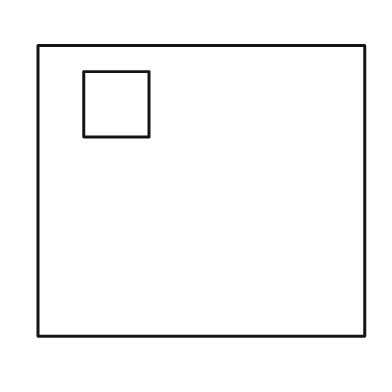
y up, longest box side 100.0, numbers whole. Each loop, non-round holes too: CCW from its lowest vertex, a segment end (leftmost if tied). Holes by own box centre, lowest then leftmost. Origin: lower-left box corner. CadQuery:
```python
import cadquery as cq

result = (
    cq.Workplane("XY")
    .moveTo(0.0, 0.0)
    .lineTo(100.0, 0.0)
    .lineTo(100.0, 89.0)
    .lineTo(0.0, 89.0)
    .close()
    .moveTo(14.0, 61.0)
    .lineTo(34.0, 61.0)
    .lineTo(34.0, 81.0)
    .lineTo(14.0, 81.0)
    .close()
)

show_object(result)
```